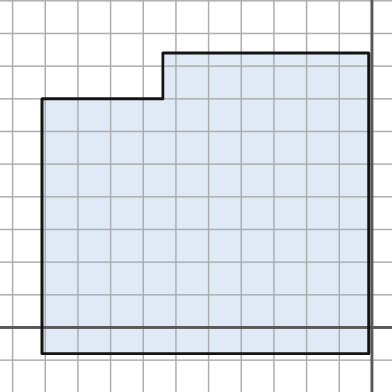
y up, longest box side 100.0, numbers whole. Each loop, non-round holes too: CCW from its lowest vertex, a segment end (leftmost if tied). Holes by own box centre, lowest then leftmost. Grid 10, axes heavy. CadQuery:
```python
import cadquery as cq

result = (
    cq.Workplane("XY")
    .moveTo(-101.0, -8.0)
    .lineTo(-1.0, -8.0)
    .lineTo(-1.0, 84.0)
    .lineTo(-64.0, 84.0)
    .lineTo(-64.0, 70.0)
    .lineTo(-101.0, 70.0)
    .close()
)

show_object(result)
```